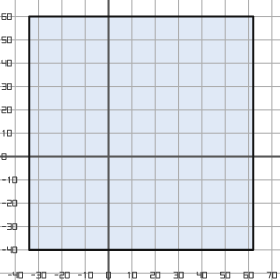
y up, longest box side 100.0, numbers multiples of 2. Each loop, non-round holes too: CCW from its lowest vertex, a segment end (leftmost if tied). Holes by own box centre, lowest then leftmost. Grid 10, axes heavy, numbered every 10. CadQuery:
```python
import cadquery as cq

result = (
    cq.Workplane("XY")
    .moveTo(-34.0, -40.0)
    .lineTo(62.0, -40.0)
    .lineTo(62.0, 60.0)
    .lineTo(-34.0, 60.0)
    .close()
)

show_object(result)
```